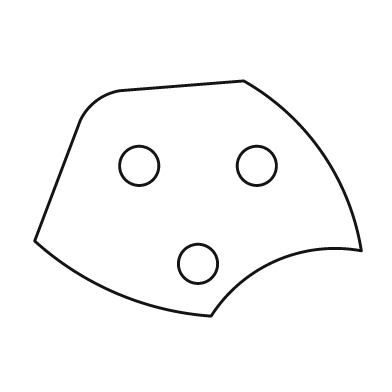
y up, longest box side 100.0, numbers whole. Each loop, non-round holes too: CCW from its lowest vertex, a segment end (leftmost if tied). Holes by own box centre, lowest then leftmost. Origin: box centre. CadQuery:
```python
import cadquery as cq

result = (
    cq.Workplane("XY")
    .moveTo(4.0, -36.0)
    .threePointArc((24.0, -19.0), (50.0, -16.0))
    .threePointArc((38.0, 14.0), (14.0, 36.0))
    .lineTo(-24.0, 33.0)
    .threePointArc((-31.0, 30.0), (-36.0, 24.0))
    .lineTo(-50.0, -13.0)
    .threePointArc((-25.0, -29.0), (4.0, -36.0))
    .close()
    .moveTo(0.0, -20.0)
    .circle(6.0)
    .moveTo(-18.0, 10.0)
    .circle(6.0)
    .moveTo(18.0, 10.0)
    .circle(6.0)
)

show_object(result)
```